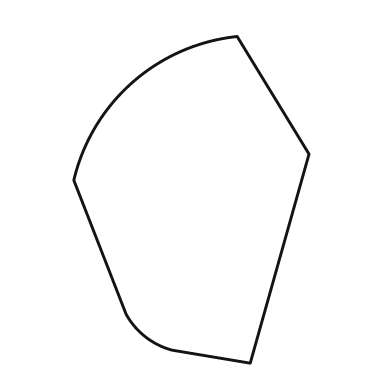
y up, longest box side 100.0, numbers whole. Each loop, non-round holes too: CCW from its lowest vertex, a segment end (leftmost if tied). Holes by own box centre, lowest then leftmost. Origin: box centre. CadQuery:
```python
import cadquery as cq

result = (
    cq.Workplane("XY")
    .moveTo(18.0, -50.0)
    .lineTo(36.0, 14.0)
    .lineTo(14.0, 50.0)
    .threePointArc((-18.0, 36.0), (-36.0, 6.0))
    .lineTo(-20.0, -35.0)
    .threePointArc((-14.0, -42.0), (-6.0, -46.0))
    .close()
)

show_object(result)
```